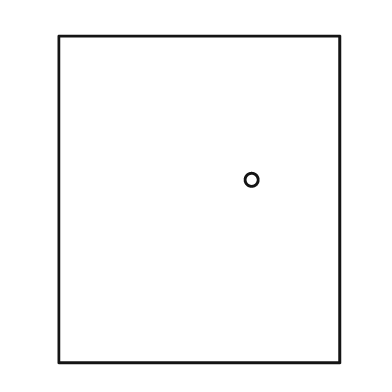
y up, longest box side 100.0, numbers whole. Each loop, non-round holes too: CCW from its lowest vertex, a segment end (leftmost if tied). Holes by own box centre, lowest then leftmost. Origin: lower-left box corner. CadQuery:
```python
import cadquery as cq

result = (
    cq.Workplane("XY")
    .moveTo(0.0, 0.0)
    .lineTo(86.0, 0.0)
    .lineTo(86.0, 100.0)
    .lineTo(0.0, 100.0)
    .close()
    .moveTo(59.0, 56.0)
    .circle(2.0)
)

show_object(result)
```